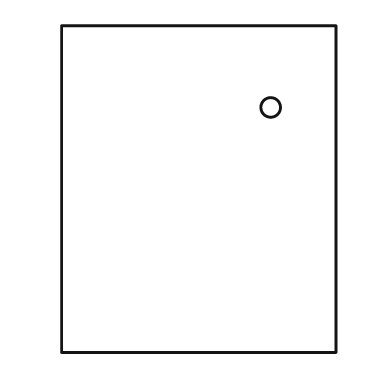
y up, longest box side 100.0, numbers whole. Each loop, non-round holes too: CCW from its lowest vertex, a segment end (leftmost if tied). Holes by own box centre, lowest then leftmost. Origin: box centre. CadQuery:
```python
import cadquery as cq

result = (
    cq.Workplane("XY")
    .moveTo(-42.0, -50.0)
    .lineTo(42.0, -50.0)
    .lineTo(42.0, 50.0)
    .lineTo(-42.0, 50.0)
    .close()
    .moveTo(22.0, 25.0)
    .circle(3.0)
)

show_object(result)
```